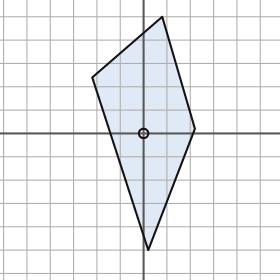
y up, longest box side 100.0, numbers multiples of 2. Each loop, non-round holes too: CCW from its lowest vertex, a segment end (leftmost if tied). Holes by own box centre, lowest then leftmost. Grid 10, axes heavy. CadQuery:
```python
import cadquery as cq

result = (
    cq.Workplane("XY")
    .moveTo(2.0, -50.0)
    .lineTo(22.0, 2.0)
    .lineTo(8.0, 50.0)
    .lineTo(-22.0, 24.0)
    .close()
    .moveTo(0.0, 0.0)
    .circle(2.0)
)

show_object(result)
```